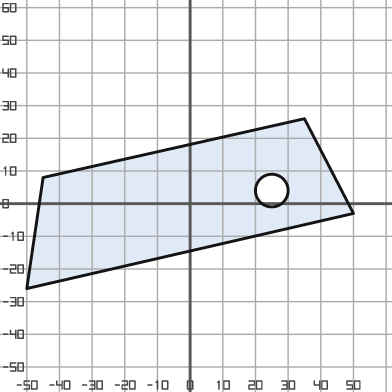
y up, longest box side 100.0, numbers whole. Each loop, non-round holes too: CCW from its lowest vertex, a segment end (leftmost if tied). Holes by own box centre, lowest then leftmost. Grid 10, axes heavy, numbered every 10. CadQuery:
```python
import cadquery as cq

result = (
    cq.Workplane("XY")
    .moveTo(-50.0, -26.0)
    .lineTo(50.0, -3.0)
    .lineTo(35.0, 26.0)
    .lineTo(-45.0, 8.0)
    .close()
    .moveTo(25.0, 4.0)
    .circle(5.0)
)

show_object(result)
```